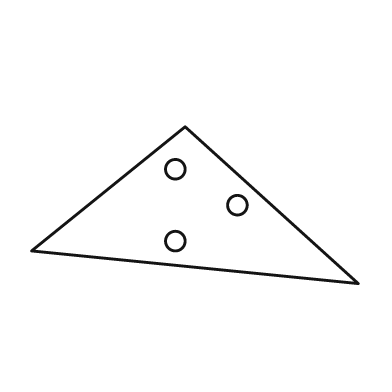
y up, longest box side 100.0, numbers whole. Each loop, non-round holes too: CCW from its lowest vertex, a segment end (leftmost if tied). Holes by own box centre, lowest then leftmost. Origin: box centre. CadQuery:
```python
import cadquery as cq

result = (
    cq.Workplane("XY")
    .moveTo(50.0, -24.0)
    .lineTo(-3.0, 24.0)
    .lineTo(-50.0, -14.0)
    .close()
    .moveTo(-6.0, -11.0)
    .circle(3.0)
    .moveTo(13.0, 0.0)
    .circle(3.0)
    .moveTo(-6.0, 11.0)
    .circle(3.0)
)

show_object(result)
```